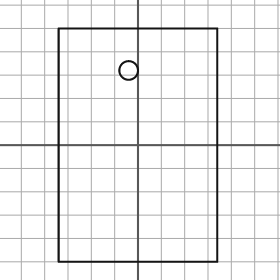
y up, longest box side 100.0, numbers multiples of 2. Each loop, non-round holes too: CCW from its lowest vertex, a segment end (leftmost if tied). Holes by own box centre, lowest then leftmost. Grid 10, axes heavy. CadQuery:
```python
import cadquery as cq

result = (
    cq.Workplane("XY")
    .moveTo(-34.0, -50.0)
    .lineTo(34.0, -50.0)
    .lineTo(34.0, 50.0)
    .lineTo(-34.0, 50.0)
    .close()
    .moveTo(-4.0, 32.0)
    .circle(4.0)
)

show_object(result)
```